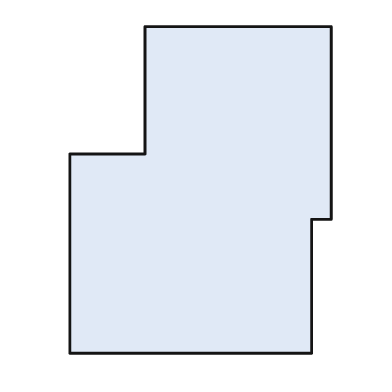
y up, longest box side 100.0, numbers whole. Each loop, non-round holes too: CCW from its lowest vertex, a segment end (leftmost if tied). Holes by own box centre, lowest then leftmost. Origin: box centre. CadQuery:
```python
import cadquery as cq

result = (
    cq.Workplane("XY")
    .moveTo(-40.0, -50.0)
    .lineTo(34.0, -50.0)
    .lineTo(34.0, -9.0)
    .lineTo(40.0, -9.0)
    .lineTo(40.0, 50.0)
    .lineTo(-17.0, 50.0)
    .lineTo(-17.0, 11.0)
    .lineTo(-40.0, 11.0)
    .close()
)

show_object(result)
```